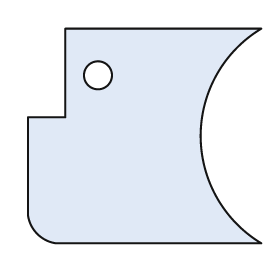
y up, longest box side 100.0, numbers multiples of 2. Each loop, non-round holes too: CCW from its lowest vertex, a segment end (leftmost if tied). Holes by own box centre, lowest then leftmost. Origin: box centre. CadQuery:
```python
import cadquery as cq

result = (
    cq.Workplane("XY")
    .moveTo(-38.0, -46.0)
    .lineTo(50.0, -46.0)
    .threePointArc((24.0, 0.0), (50.0, 46.0))
    .lineTo(-34.0, 46.0)
    .lineTo(-34.0, 8.0)
    .lineTo(-50.0, 8.0)
    .lineTo(-50.0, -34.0)
    .threePointArc((-46.0, -42.0), (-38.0, -46.0))
    .close()
    .moveTo(-20.0, 26.0)
    .circle(6.0)
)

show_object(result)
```